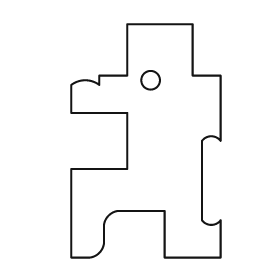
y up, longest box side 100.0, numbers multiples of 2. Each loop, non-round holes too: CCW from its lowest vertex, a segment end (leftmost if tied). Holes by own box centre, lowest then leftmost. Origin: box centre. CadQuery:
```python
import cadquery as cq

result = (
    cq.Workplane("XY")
    .moveTo(-32.0, -50.0)
    .lineTo(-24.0, -50.0)
    .threePointArc((-20.0, -48.0), (-18.0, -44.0))
    .lineTo(-18.0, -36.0)
    .threePointArc((-16.0, -32.0), (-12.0, -30.0))
    .lineTo(8.0, -30.0)
    .lineTo(8.0, -50.0)
    .lineTo(32.0, -50.0)
    .lineTo(32.0, -34.0)
    .threePointArc((28.0, -36.0), (24.0, -34.0))
    .lineTo(24.0, 0.0)
    .threePointArc((28.0, 2.0), (32.0, 0.0))
    .lineTo(32.0, 28.0)
    .lineTo(20.0, 28.0)
    .lineTo(20.0, 50.0)
    .lineTo(-8.0, 50.0)
    .lineTo(-8.0, 28.0)
    .lineTo(-20.0, 28.0)
    .lineTo(-20.0, 24.0)
    .threePointArc((-26.0, 26.0), (-32.0, 24.0))
    .lineTo(-32.0, 12.0)
    .lineTo(-8.0, 12.0)
    .lineTo(-8.0, -12.0)
    .lineTo(-32.0, -12.0)
    .close()
    .moveTo(2.0, 26.0)
    .circle(4.0)
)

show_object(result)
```